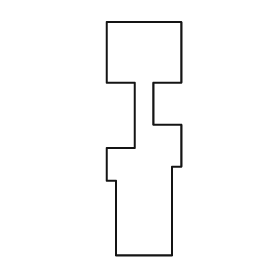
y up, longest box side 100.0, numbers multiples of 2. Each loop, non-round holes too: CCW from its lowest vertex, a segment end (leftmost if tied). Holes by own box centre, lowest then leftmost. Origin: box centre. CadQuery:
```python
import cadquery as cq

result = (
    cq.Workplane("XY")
    .moveTo(-12.0, -50.0)
    .lineTo(12.0, -50.0)
    .lineTo(12.0, -12.0)
    .lineTo(16.0, -12.0)
    .lineTo(16.0, 6.0)
    .lineTo(4.0, 6.0)
    .lineTo(4.0, 24.0)
    .lineTo(16.0, 24.0)
    .lineTo(16.0, 50.0)
    .lineTo(-16.0, 50.0)
    .lineTo(-16.0, 24.0)
    .lineTo(-4.0, 24.0)
    .lineTo(-4.0, -4.0)
    .lineTo(-16.0, -4.0)
    .lineTo(-16.0, -18.0)
    .lineTo(-12.0, -18.0)
    .close()
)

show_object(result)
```